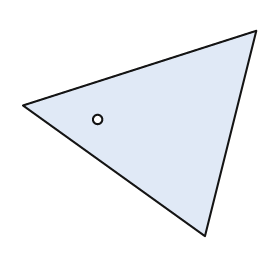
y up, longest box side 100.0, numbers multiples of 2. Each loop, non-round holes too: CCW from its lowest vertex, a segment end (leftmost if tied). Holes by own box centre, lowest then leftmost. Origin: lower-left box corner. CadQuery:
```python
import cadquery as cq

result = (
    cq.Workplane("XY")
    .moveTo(78.0, 0.0)
    .lineTo(100.0, 88.0)
    .lineTo(0.0, 56.0)
    .close()
    .moveTo(32.0, 50.0)
    .circle(2.0)
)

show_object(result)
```